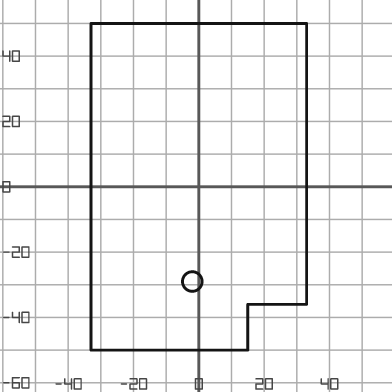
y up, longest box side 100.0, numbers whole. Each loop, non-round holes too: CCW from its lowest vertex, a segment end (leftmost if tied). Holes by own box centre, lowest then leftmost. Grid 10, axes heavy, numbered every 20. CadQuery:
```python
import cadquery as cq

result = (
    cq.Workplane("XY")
    .moveTo(-33.0, -50.0)
    .lineTo(15.0, -50.0)
    .lineTo(15.0, -36.0)
    .lineTo(33.0, -36.0)
    .lineTo(33.0, 50.0)
    .lineTo(-33.0, 50.0)
    .close()
    .moveTo(-2.0, -29.0)
    .circle(3.0)
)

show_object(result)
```